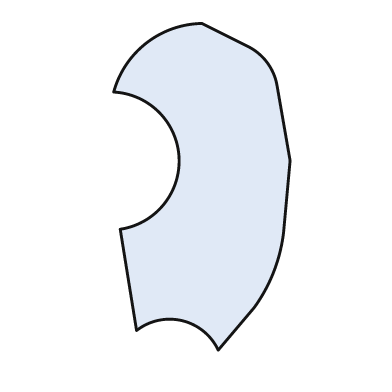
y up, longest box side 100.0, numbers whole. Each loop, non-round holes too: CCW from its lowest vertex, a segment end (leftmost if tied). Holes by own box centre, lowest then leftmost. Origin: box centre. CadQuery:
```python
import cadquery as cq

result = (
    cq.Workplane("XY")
    .moveTo(5.0, -50.0)
    .lineTo(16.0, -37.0)
    .threePointArc((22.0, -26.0), (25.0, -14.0))
    .lineTo(27.0, 8.0)
    .lineTo(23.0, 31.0)
    .threePointArc((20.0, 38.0), (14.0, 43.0))
    .lineTo(0.0, 50.0)
    .threePointArc((-17.0, 44.0), (-27.0, 29.0))
    .threePointArc((-7.0, 9.0), (-25.0, -13.0))
    .lineTo(-20.0, -44.0)
    .threePointArc((-6.0, -41.0), (5.0, -50.0))
    .close()
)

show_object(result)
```